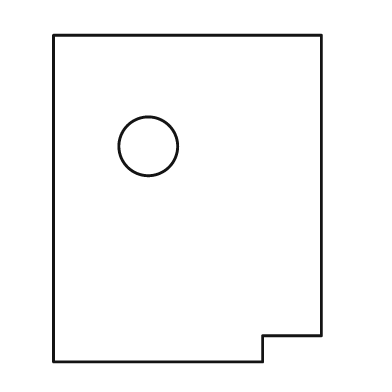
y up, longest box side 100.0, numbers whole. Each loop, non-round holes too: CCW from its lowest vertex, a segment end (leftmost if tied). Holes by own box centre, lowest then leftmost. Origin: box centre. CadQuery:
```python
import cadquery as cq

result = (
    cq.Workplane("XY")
    .moveTo(-41.0, -50.0)
    .lineTo(23.0, -50.0)
    .lineTo(23.0, -42.0)
    .lineTo(41.0, -42.0)
    .lineTo(41.0, 50.0)
    .lineTo(-41.0, 50.0)
    .close()
    .moveTo(-12.0, 16.0)
    .circle(9.0)
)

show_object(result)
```